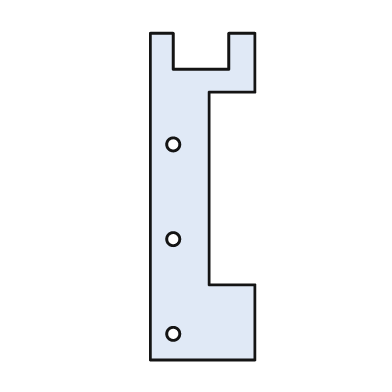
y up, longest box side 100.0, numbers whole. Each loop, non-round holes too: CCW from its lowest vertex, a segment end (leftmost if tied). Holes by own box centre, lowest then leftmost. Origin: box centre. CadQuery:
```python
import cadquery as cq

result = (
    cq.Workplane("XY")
    .moveTo(-16.0, -50.0)
    .lineTo(16.0, -50.0)
    .lineTo(16.0, -27.0)
    .lineTo(2.0, -27.0)
    .lineTo(2.0, 32.0)
    .lineTo(16.0, 32.0)
    .lineTo(16.0, 50.0)
    .lineTo(8.0, 50.0)
    .lineTo(8.0, 39.0)
    .lineTo(-9.0, 39.0)
    .lineTo(-9.0, 50.0)
    .lineTo(-16.0, 50.0)
    .close()
    .moveTo(-9.0, -42.0)
    .circle(2.0)
    .moveTo(-9.0, -13.0)
    .circle(2.0)
    .moveTo(-9.0, 16.0)
    .circle(2.0)
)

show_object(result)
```